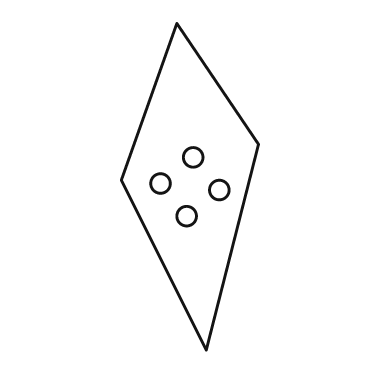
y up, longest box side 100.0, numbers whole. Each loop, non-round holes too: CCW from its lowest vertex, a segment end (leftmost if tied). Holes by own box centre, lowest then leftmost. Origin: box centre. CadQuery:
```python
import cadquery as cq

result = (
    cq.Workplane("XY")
    .moveTo(5.0, -50.0)
    .lineTo(21.0, 13.0)
    .lineTo(-4.0, 50.0)
    .lineTo(-21.0, 2.0)
    .close()
    .moveTo(-1.0, -9.0)
    .circle(3.0)
    .moveTo(9.0, -1.0)
    .circle(3.0)
    .moveTo(-9.0, 1.0)
    .circle(3.0)
    .moveTo(1.0, 9.0)
    .circle(3.0)
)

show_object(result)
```